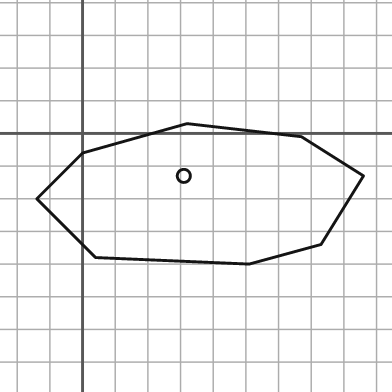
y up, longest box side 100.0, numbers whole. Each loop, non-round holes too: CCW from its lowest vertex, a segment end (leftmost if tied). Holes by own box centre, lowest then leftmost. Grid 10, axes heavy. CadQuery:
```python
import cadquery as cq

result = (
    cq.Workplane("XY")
    .moveTo(51.0, -40.0)
    .lineTo(73.0, -34.0)
    .lineTo(86.0, -13.0)
    .lineTo(67.0, -1.0)
    .lineTo(32.0, 3.0)
    .lineTo(0.0, -6.0)
    .lineTo(-14.0, -20.0)
    .lineTo(4.0, -38.0)
    .close()
    .moveTo(31.0, -13.0)
    .circle(2.0)
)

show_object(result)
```